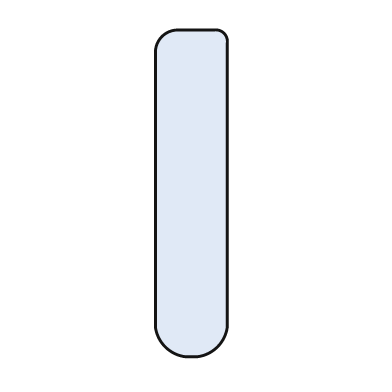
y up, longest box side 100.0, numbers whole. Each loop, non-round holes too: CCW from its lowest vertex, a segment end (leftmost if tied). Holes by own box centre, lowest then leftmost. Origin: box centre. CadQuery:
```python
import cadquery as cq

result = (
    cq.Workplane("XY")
    .moveTo(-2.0, -50.0)
    .lineTo(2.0, -50.0)
    .threePointArc((8.0, -47.0), (11.0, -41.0))
    .lineTo(11.0, 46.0)
    .threePointArc((10.0, 49.0), (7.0, 50.0))
    .lineTo(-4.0, 50.0)
    .threePointArc((-9.0, 48.0), (-11.0, 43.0))
    .lineTo(-11.0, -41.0)
    .threePointArc((-8.0, -47.0), (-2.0, -50.0))
    .close()
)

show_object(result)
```